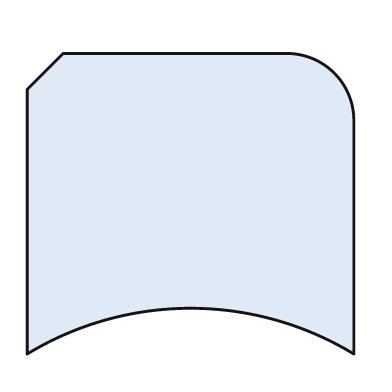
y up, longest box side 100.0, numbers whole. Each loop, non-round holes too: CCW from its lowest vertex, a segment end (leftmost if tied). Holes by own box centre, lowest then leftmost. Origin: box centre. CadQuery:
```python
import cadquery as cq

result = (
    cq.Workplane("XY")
    .moveTo(-50.0, -46.0)
    .threePointArc((0.0, -32.0), (50.0, -46.0))
    .lineTo(50.0, 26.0)
    .threePointArc((44.0, 40.0), (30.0, 46.0))
    .lineTo(-39.0, 46.0)
    .lineTo(-50.0, 35.0)
    .close()
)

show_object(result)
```